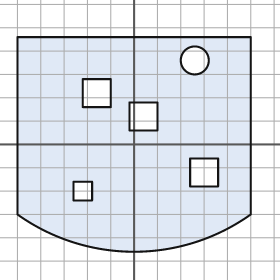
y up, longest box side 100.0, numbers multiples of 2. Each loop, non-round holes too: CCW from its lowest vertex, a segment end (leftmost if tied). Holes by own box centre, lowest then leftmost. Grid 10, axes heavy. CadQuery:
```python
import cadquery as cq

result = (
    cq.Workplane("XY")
    .moveTo(-50.0, -30.0)
    .threePointArc((0.0, -46.0), (50.0, -30.0))
    .lineTo(50.0, 46.0)
    .lineTo(-50.0, 46.0)
    .close()
    .moveTo(-26.0, -24.0)
    .lineTo(-18.0, -24.0)
    .lineTo(-18.0, -16.0)
    .lineTo(-26.0, -16.0)
    .close()
    .moveTo(24.0, -18.0)
    .lineTo(36.0, -18.0)
    .lineTo(36.0, -6.0)
    .lineTo(24.0, -6.0)
    .close()
    .moveTo(-2.0, 6.0)
    .lineTo(10.0, 6.0)
    .lineTo(10.0, 18.0)
    .lineTo(-2.0, 18.0)
    .close()
    .moveTo(-22.0, 16.0)
    .lineTo(-10.0, 16.0)
    .lineTo(-10.0, 28.0)
    .lineTo(-22.0, 28.0)
    .close()
    .moveTo(26.0, 36.0)
    .circle(6.0)
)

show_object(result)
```